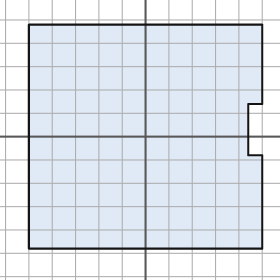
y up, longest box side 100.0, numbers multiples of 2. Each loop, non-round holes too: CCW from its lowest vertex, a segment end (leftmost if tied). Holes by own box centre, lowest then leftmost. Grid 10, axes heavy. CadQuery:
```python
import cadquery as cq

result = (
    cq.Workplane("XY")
    .moveTo(-50.0, -48.0)
    .lineTo(50.0, -48.0)
    .lineTo(50.0, -8.0)
    .lineTo(44.0, -8.0)
    .lineTo(44.0, 14.0)
    .lineTo(50.0, 14.0)
    .lineTo(50.0, 48.0)
    .lineTo(-50.0, 48.0)
    .close()
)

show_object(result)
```